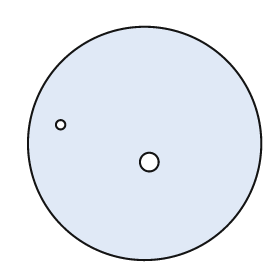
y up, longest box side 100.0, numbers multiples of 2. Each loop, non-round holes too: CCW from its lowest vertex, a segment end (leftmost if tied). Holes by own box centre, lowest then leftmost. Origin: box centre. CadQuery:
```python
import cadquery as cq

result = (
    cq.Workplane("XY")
    .moveTo(0.0, 0.0)
    .circle(50.0)
    .moveTo(2.0, -8.0)
    .circle(4.0)
    .moveTo(-36.0, 8.0)
    .circle(2.0)
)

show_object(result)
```